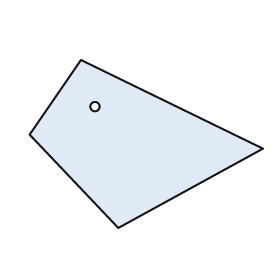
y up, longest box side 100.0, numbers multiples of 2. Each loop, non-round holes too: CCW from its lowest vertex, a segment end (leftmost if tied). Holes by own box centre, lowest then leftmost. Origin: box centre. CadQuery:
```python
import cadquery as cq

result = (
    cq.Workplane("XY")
    .moveTo(-12.0, -36.0)
    .lineTo(50.0, -2.0)
    .lineTo(-28.0, 36.0)
    .lineTo(-50.0, 4.0)
    .close()
    .moveTo(-22.0, 16.0)
    .circle(2.0)
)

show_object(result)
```